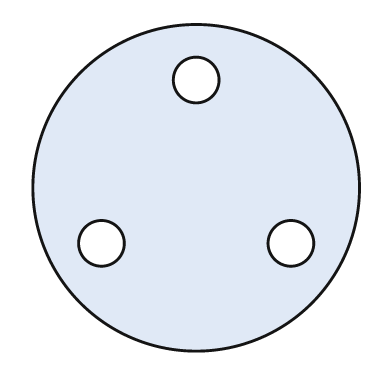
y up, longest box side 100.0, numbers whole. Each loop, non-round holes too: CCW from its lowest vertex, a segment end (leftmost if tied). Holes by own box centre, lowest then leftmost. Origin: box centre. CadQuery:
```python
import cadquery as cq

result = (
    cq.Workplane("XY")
    .moveTo(0.0, 0.0)
    .circle(50.0)
    .moveTo(-29.0, -17.0)
    .circle(7.0)
    .moveTo(29.0, -17.0)
    .circle(7.0)
    .moveTo(0.0, 33.0)
    .circle(7.0)
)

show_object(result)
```